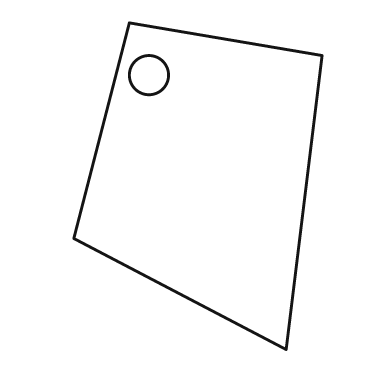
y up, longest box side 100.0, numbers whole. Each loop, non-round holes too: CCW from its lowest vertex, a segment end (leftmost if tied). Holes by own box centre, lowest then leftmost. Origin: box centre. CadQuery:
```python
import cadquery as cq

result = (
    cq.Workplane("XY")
    .moveTo(27.0, -50.0)
    .lineTo(38.0, 40.0)
    .lineTo(-21.0, 50.0)
    .lineTo(-38.0, -16.0)
    .close()
    .moveTo(-15.0, 34.0)
    .circle(6.0)
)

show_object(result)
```